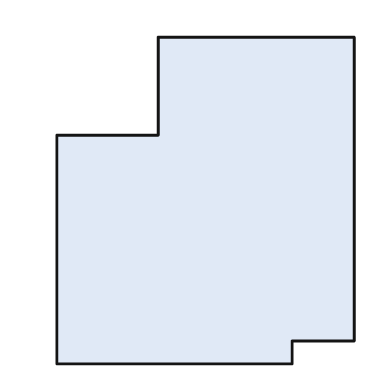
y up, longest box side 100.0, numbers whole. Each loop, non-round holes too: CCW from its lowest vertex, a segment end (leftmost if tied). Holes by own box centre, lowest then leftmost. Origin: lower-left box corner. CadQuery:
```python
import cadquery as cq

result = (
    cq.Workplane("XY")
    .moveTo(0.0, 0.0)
    .lineTo(72.0, 0.0)
    .lineTo(72.0, 7.0)
    .lineTo(91.0, 7.0)
    .lineTo(91.0, 100.0)
    .lineTo(31.0, 100.0)
    .lineTo(31.0, 70.0)
    .lineTo(0.0, 70.0)
    .close()
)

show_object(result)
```